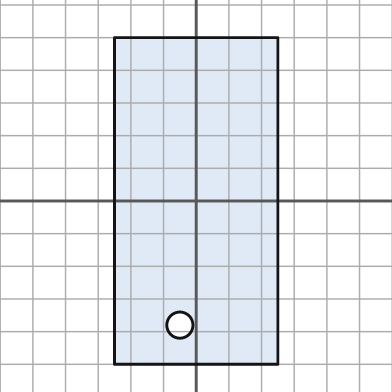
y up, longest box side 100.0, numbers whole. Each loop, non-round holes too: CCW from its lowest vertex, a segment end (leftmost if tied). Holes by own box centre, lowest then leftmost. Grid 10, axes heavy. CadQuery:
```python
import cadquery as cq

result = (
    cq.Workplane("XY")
    .moveTo(-25.0, -50.0)
    .lineTo(25.0, -50.0)
    .lineTo(25.0, 50.0)
    .lineTo(-25.0, 50.0)
    .close()
    .moveTo(-5.0, -38.0)
    .circle(4.0)
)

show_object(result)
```